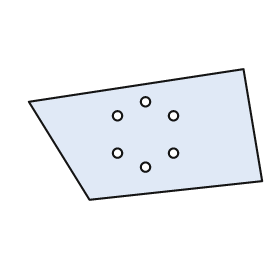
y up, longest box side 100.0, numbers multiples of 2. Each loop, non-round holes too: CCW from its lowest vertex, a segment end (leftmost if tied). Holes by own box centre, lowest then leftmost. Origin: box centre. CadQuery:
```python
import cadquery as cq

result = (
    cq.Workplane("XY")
    .moveTo(-24.0, -28.0)
    .lineTo(50.0, -20.0)
    .lineTo(42.0, 28.0)
    .lineTo(-50.0, 14.0)
    .close()
    .moveTo(0.0, -14.0)
    .circle(2.0)
    .moveTo(-12.0, -8.0)
    .circle(2.0)
    .moveTo(12.0, -8.0)
    .circle(2.0)
    .moveTo(-12.0, 8.0)
    .circle(2.0)
    .moveTo(12.0, 8.0)
    .circle(2.0)
    .moveTo(0.0, 14.0)
    .circle(2.0)
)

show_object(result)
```